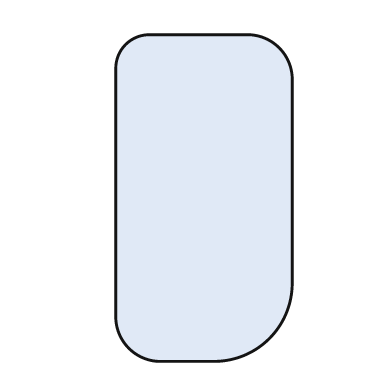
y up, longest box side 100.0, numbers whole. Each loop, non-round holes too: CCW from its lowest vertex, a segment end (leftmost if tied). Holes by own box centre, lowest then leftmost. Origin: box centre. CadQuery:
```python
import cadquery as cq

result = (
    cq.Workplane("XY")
    .moveTo(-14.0, -50.0)
    .lineTo(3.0, -50.0)
    .threePointArc((20.0, -43.0), (27.0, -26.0))
    .lineTo(27.0, 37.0)
    .threePointArc((23.0, 46.0), (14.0, 50.0))
    .lineTo(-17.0, 50.0)
    .threePointArc((-24.0, 47.0), (-27.0, 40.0))
    .lineTo(-27.0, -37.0)
    .threePointArc((-23.0, -46.0), (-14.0, -50.0))
    .close()
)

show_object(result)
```